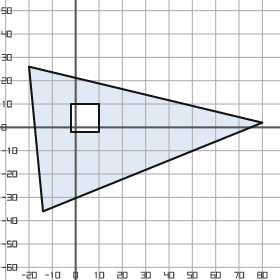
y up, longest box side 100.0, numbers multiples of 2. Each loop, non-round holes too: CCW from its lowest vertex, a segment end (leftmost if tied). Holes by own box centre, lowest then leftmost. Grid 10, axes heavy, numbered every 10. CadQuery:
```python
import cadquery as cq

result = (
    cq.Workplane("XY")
    .moveTo(-14.0, -36.0)
    .lineTo(80.0, 2.0)
    .lineTo(-20.0, 26.0)
    .close()
    .moveTo(-2.0, -2.0)
    .lineTo(10.0, -2.0)
    .lineTo(10.0, 10.0)
    .lineTo(-2.0, 10.0)
    .close()
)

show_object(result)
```